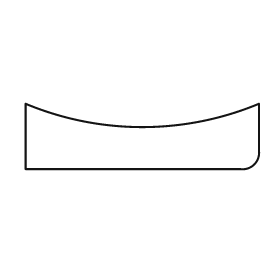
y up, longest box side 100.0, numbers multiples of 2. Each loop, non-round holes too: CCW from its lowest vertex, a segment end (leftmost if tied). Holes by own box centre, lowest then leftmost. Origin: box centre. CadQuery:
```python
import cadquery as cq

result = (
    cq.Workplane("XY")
    .moveTo(-50.0, -14.0)
    .lineTo(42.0, -14.0)
    .threePointArc((48.0, -12.0), (50.0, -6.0))
    .lineTo(50.0, 14.0)
    .threePointArc((0.0, 4.0), (-50.0, 14.0))
    .close()
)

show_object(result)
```